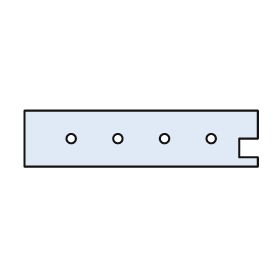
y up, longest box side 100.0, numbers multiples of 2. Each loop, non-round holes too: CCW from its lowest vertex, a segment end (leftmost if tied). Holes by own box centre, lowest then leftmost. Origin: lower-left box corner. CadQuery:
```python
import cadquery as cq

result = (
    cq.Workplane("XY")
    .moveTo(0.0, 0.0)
    .lineTo(100.0, 0.0)
    .lineTo(100.0, 4.0)
    .lineTo(92.0, 4.0)
    .lineTo(92.0, 12.0)
    .lineTo(100.0, 12.0)
    .lineTo(100.0, 24.0)
    .lineTo(0.0, 24.0)
    .close()
    .moveTo(20.0, 12.0)
    .circle(2.0)
    .moveTo(40.0, 12.0)
    .circle(2.0)
    .moveTo(60.0, 12.0)
    .circle(2.0)
    .moveTo(80.0, 12.0)
    .circle(2.0)
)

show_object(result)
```